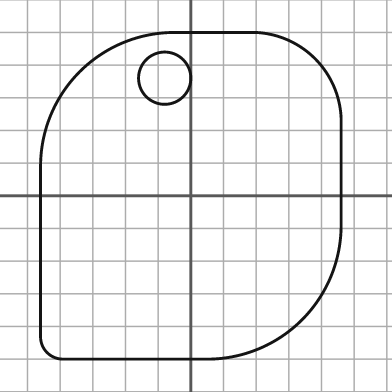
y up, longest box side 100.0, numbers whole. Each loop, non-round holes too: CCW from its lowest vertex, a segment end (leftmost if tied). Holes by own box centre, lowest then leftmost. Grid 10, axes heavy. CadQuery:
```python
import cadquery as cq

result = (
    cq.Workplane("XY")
    .moveTo(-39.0, -50.0)
    .lineTo(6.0, -50.0)
    .threePointArc((34.0, -38.0), (46.0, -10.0))
    .lineTo(46.0, 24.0)
    .threePointArc((38.0, 42.0), (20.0, 50.0))
    .lineTo(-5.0, 50.0)
    .threePointArc((-34.0, 38.0), (-46.0, 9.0))
    .lineTo(-46.0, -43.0)
    .threePointArc((-44.0, -48.0), (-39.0, -50.0))
    .close()
    .moveTo(-8.0, 36.0)
    .circle(8.0)
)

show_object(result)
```